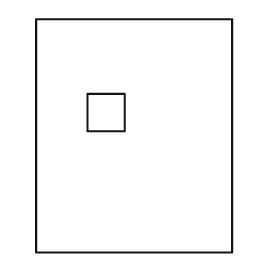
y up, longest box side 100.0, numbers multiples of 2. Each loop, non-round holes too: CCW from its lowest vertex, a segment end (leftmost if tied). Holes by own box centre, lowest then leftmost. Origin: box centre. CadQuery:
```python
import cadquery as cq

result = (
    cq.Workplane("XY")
    .moveTo(-42.0, -50.0)
    .lineTo(42.0, -50.0)
    .lineTo(42.0, 50.0)
    .lineTo(-42.0, 50.0)
    .close()
    .moveTo(-20.0, 2.0)
    .lineTo(-4.0, 2.0)
    .lineTo(-4.0, 18.0)
    .lineTo(-20.0, 18.0)
    .close()
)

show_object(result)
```